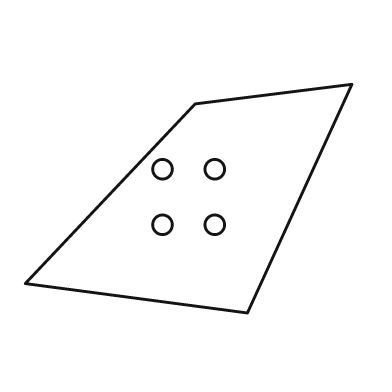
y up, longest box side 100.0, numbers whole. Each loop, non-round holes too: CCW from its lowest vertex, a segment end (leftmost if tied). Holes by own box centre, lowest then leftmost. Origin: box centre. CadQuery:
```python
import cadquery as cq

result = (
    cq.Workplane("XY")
    .moveTo(18.0, -35.0)
    .lineTo(50.0, 35.0)
    .lineTo(2.0, 29.0)
    .lineTo(-50.0, -26.0)
    .close()
    .moveTo(-8.0, -8.0)
    .circle(3.0)
    .moveTo(8.0, -8.0)
    .circle(3.0)
    .moveTo(-8.0, 9.0)
    .circle(3.0)
    .moveTo(8.0, 9.0)
    .circle(3.0)
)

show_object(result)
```